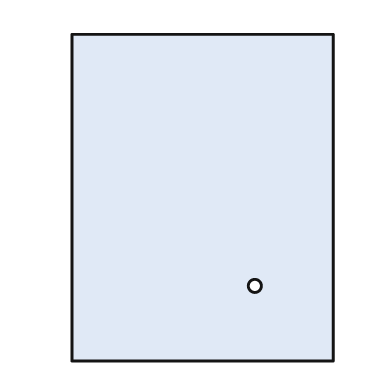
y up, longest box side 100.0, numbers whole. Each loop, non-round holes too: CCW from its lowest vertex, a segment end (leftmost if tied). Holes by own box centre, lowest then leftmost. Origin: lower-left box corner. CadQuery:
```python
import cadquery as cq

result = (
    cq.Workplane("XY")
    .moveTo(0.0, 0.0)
    .lineTo(80.0, 0.0)
    .lineTo(80.0, 100.0)
    .lineTo(0.0, 100.0)
    .close()
    .moveTo(56.0, 23.0)
    .circle(2.0)
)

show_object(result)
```